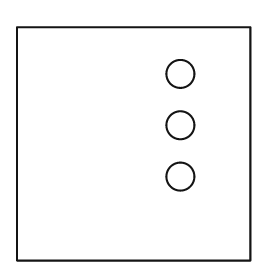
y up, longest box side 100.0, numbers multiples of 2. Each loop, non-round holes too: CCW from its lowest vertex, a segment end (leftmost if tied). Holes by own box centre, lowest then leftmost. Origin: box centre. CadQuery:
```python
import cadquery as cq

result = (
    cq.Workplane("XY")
    .moveTo(-50.0, -50.0)
    .lineTo(50.0, -50.0)
    .lineTo(50.0, 50.0)
    .lineTo(-50.0, 50.0)
    .close()
    .moveTo(20.0, -14.0)
    .circle(6.0)
    .moveTo(20.0, 8.0)
    .circle(6.0)
    .moveTo(20.0, 30.0)
    .circle(6.0)
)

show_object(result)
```